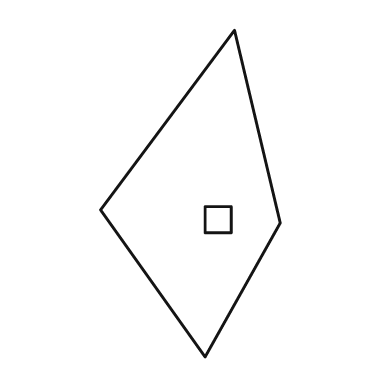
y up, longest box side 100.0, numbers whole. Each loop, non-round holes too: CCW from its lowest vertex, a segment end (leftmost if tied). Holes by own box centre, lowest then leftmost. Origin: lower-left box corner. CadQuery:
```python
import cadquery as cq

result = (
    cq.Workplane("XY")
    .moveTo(32.0, 0.0)
    .lineTo(55.0, 41.0)
    .lineTo(41.0, 100.0)
    .lineTo(0.0, 45.0)
    .close()
    .moveTo(32.0, 38.0)
    .lineTo(40.0, 38.0)
    .lineTo(40.0, 46.0)
    .lineTo(32.0, 46.0)
    .close()
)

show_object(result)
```